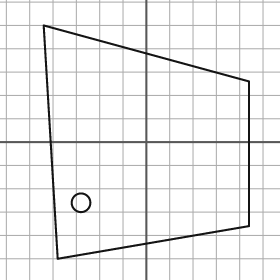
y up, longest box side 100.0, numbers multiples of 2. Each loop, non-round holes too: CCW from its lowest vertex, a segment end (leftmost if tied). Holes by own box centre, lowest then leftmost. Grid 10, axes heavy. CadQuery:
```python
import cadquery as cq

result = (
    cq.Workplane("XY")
    .moveTo(-38.0, -50.0)
    .lineTo(44.0, -36.0)
    .lineTo(44.0, 26.0)
    .lineTo(-44.0, 50.0)
    .close()
    .moveTo(-28.0, -26.0)
    .circle(4.0)
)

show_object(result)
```